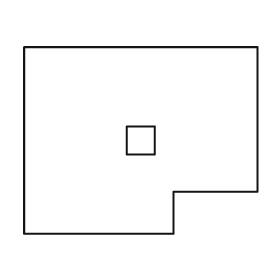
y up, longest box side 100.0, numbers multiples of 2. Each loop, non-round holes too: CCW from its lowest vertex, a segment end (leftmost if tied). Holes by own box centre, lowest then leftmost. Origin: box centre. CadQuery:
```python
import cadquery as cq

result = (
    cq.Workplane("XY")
    .moveTo(-50.0, -40.0)
    .lineTo(14.0, -40.0)
    .lineTo(14.0, -22.0)
    .lineTo(50.0, -22.0)
    .lineTo(50.0, 40.0)
    .lineTo(-50.0, 40.0)
    .close()
    .moveTo(-6.0, -6.0)
    .lineTo(6.0, -6.0)
    .lineTo(6.0, 6.0)
    .lineTo(-6.0, 6.0)
    .close()
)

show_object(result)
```